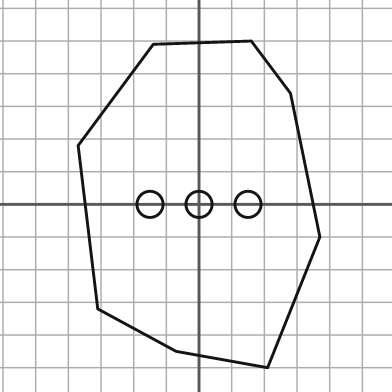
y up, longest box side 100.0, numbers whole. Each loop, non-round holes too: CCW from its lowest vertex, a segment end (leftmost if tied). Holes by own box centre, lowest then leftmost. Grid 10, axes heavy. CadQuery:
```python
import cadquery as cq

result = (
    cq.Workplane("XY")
    .moveTo(21.0, -50.0)
    .lineTo(37.0, -10.0)
    .lineTo(28.0, 34.0)
    .lineTo(16.0, 50.0)
    .lineTo(-14.0, 49.0)
    .lineTo(-37.0, 18.0)
    .lineTo(-31.0, -32.0)
    .lineTo(-7.0, -45.0)
    .close()
    .moveTo(-15.0, 0.0)
    .circle(4.0)
    .moveTo(0.0, 0.0)
    .circle(4.0)
    .moveTo(15.0, 0.0)
    .circle(4.0)
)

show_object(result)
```